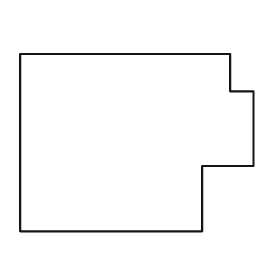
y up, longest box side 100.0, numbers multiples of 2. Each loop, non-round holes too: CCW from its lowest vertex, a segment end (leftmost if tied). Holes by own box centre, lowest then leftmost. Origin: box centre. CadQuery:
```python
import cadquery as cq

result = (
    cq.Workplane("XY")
    .moveTo(-50.0, -38.0)
    .lineTo(28.0, -38.0)
    .lineTo(28.0, -10.0)
    .lineTo(50.0, -10.0)
    .lineTo(50.0, 22.0)
    .lineTo(40.0, 22.0)
    .lineTo(40.0, 38.0)
    .lineTo(-50.0, 38.0)
    .close()
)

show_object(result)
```